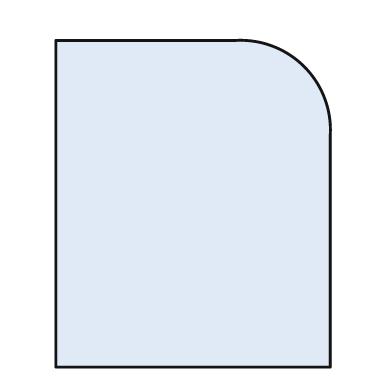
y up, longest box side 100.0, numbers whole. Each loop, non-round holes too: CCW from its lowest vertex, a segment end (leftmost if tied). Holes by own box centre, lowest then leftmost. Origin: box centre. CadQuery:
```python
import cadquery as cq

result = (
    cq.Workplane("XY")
    .moveTo(-42.0, -50.0)
    .lineTo(42.0, -50.0)
    .lineTo(42.0, 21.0)
    .threePointArc((34.0, 42.0), (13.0, 50.0))
    .lineTo(-42.0, 50.0)
    .close()
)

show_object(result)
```